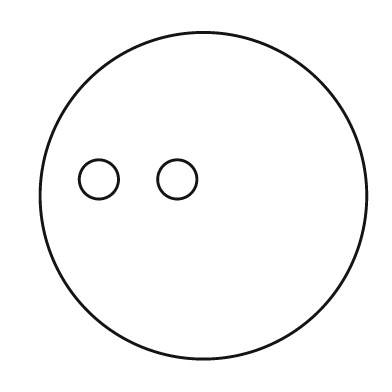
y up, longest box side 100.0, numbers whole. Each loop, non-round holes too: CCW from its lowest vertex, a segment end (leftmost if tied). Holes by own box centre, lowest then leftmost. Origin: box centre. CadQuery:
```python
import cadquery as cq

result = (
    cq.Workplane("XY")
    .moveTo(0.0, 0.0)
    .circle(50.0)
    .moveTo(-32.0, 5.0)
    .circle(6.0)
    .moveTo(-8.0, 5.0)
    .circle(6.0)
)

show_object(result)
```